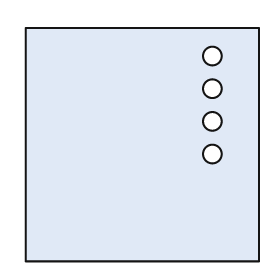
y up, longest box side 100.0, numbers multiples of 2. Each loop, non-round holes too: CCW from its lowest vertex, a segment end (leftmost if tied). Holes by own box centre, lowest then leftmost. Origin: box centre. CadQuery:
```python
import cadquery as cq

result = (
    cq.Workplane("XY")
    .moveTo(-50.0, -50.0)
    .lineTo(50.0, -50.0)
    .lineTo(50.0, 50.0)
    .lineTo(-50.0, 50.0)
    .close()
    .moveTo(30.0, -4.0)
    .circle(4.0)
    .moveTo(30.0, 10.0)
    .circle(4.0)
    .moveTo(30.0, 24.0)
    .circle(4.0)
    .moveTo(30.0, 38.0)
    .circle(4.0)
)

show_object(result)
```